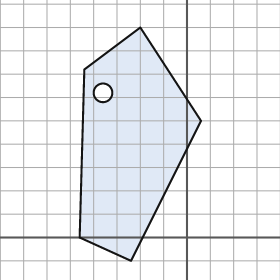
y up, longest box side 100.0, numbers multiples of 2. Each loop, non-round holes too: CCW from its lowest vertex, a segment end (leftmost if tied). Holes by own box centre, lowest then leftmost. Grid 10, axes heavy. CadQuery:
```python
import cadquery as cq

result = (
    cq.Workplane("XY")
    .moveTo(-24.0, -10.0)
    .lineTo(6.0, 50.0)
    .lineTo(-20.0, 90.0)
    .lineTo(-44.0, 72.0)
    .lineTo(-46.0, 0.0)
    .close()
    .moveTo(-36.0, 62.0)
    .circle(4.0)
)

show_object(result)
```